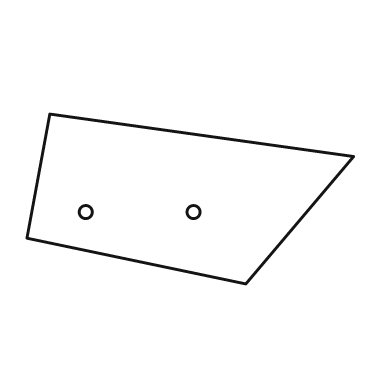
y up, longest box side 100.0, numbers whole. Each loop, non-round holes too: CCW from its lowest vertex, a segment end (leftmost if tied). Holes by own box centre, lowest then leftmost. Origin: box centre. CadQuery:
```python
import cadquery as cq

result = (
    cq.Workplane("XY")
    .moveTo(17.0, -26.0)
    .lineTo(50.0, 13.0)
    .lineTo(-43.0, 26.0)
    .lineTo(-50.0, -12.0)
    .close()
    .moveTo(-32.0, -4.0)
    .circle(2.0)
    .moveTo(1.0, -4.0)
    .circle(2.0)
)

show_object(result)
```